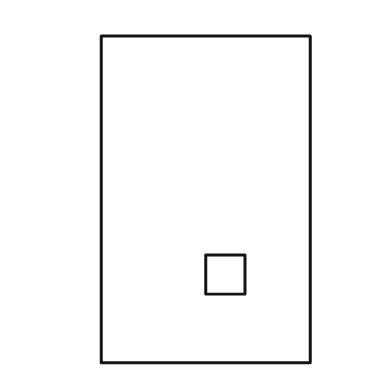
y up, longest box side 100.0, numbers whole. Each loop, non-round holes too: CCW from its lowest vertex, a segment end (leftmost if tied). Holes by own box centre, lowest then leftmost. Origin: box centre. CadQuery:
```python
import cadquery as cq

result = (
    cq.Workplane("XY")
    .moveTo(-32.0, -50.0)
    .lineTo(32.0, -50.0)
    .lineTo(32.0, 50.0)
    .lineTo(-32.0, 50.0)
    .close()
    .moveTo(0.0, -29.0)
    .lineTo(12.0, -29.0)
    .lineTo(12.0, -17.0)
    .lineTo(0.0, -17.0)
    .close()
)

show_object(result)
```